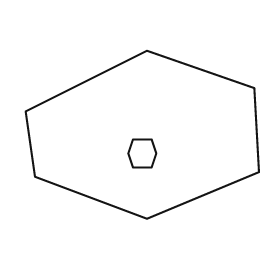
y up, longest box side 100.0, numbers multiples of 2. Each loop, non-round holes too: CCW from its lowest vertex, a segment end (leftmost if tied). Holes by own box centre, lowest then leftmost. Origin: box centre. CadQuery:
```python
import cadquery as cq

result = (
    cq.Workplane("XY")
    .moveTo(2.0, -36.0)
    .lineTo(50.0, -16.0)
    .lineTo(48.0, 20.0)
    .lineTo(2.0, 36.0)
    .lineTo(-50.0, 10.0)
    .lineTo(-46.0, -18.0)
    .close()
    .moveTo(-4.0, -14.0)
    .lineTo(4.0, -14.0)
    .lineTo(6.0, -8.0)
    .lineTo(4.0, -2.0)
    .lineTo(-4.0, -2.0)
    .lineTo(-6.0, -8.0)
    .close()
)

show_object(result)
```